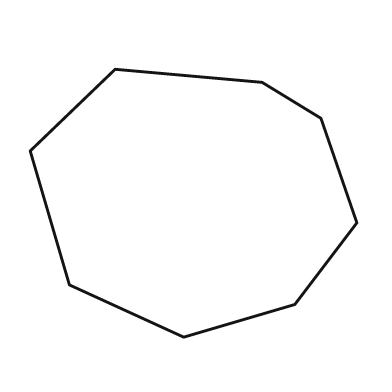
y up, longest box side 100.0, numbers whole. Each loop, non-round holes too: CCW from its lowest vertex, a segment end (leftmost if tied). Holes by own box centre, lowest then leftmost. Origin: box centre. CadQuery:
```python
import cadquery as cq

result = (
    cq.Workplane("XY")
    .moveTo(-3.0, -41.0)
    .lineTo(31.0, -31.0)
    .lineTo(50.0, -6.0)
    .lineTo(39.0, 26.0)
    .lineTo(21.0, 37.0)
    .lineTo(-24.0, 41.0)
    .lineTo(-50.0, 16.0)
    .lineTo(-38.0, -25.0)
    .close()
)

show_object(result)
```